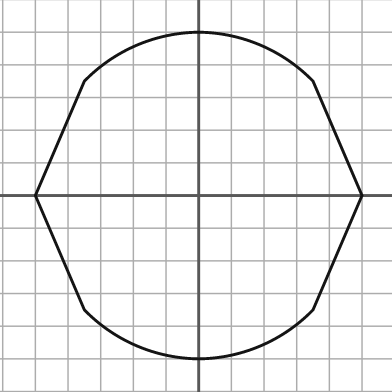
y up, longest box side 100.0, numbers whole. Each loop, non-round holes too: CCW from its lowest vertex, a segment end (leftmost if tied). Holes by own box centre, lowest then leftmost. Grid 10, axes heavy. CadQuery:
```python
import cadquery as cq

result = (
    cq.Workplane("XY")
    .moveTo(0.0, -50.0)
    .threePointArc((19.0, -46.0), (35.0, -35.0))
    .lineTo(50.0, 0.0)
    .lineTo(35.0, 35.0)
    .threePointArc((19.0, 46.0), (0.0, 50.0))
    .threePointArc((-19.0, 46.0), (-35.0, 35.0))
    .lineTo(-50.0, 0.0)
    .lineTo(-35.0, -35.0)
    .threePointArc((-19.0, -46.0), (0.0, -50.0))
    .close()
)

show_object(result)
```